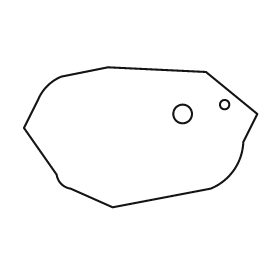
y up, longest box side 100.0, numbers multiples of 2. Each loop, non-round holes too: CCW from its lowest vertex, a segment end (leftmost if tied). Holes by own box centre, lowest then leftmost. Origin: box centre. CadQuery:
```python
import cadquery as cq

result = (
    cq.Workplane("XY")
    .moveTo(-12.0, -30.0)
    .lineTo(30.0, -22.0)
    .threePointArc((40.0, -14.0), (44.0, -2.0))
    .lineTo(50.0, 10.0)
    .lineTo(28.0, 28.0)
    .lineTo(-14.0, 30.0)
    .lineTo(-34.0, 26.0)
    .threePointArc((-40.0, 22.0), (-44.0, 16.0))
    .lineTo(-50.0, 4.0)
    .lineTo(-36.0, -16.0)
    .threePointArc((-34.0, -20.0), (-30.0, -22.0))
    .close()
    .moveTo(18.0, 10.0)
    .circle(4.0)
    .moveTo(36.0, 14.0)
    .circle(2.0)
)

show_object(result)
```